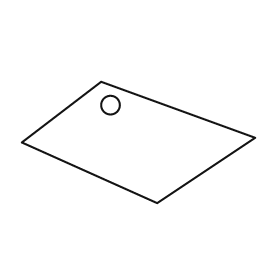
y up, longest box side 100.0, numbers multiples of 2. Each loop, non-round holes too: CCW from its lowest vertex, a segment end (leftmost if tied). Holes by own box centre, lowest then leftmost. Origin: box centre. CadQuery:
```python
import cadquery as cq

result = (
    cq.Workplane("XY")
    .moveTo(8.0, -26.0)
    .lineTo(50.0, 2.0)
    .lineTo(-16.0, 26.0)
    .lineTo(-50.0, 0.0)
    .close()
    .moveTo(-12.0, 16.0)
    .circle(4.0)
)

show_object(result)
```